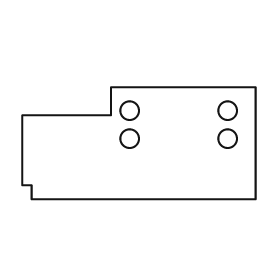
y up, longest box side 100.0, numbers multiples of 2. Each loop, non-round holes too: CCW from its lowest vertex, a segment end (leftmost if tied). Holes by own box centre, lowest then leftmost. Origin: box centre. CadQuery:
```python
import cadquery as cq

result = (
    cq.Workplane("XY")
    .moveTo(-46.0, -24.0)
    .lineTo(50.0, -24.0)
    .lineTo(50.0, 24.0)
    .lineTo(-12.0, 24.0)
    .lineTo(-12.0, 12.0)
    .lineTo(-50.0, 12.0)
    .lineTo(-50.0, -18.0)
    .lineTo(-46.0, -18.0)
    .close()
    .moveTo(-4.0, 2.0)
    .circle(4.0)
    .moveTo(38.0, 2.0)
    .circle(4.0)
    .moveTo(-4.0, 14.0)
    .circle(4.0)
    .moveTo(38.0, 14.0)
    .circle(4.0)
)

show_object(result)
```